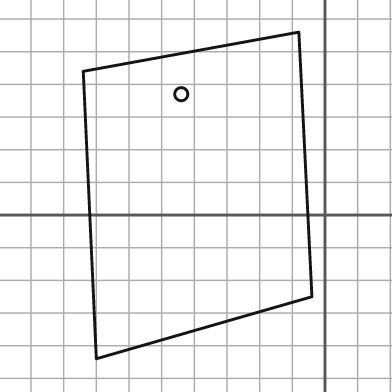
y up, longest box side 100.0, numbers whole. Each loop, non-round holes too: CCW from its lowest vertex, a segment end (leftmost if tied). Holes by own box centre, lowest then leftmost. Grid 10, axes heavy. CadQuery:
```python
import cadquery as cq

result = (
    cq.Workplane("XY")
    .moveTo(-70.0, -44.0)
    .lineTo(-4.0, -25.0)
    .lineTo(-8.0, 56.0)
    .lineTo(-74.0, 44.0)
    .close()
    .moveTo(-44.0, 37.0)
    .circle(2.0)
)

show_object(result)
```